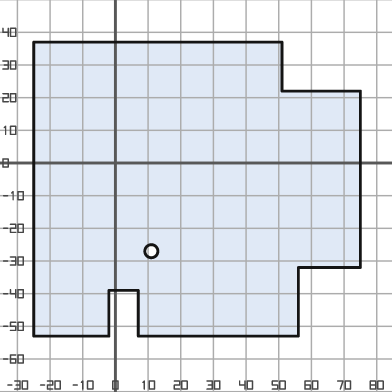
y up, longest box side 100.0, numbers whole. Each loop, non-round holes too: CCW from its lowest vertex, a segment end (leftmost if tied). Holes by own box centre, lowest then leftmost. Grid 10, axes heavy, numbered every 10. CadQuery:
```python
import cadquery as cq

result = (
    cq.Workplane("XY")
    .moveTo(-25.0, -53.0)
    .lineTo(-2.0, -53.0)
    .lineTo(-2.0, -39.0)
    .lineTo(7.0, -39.0)
    .lineTo(7.0, -53.0)
    .lineTo(56.0, -53.0)
    .lineTo(56.0, -32.0)
    .lineTo(75.0, -32.0)
    .lineTo(75.0, 22.0)
    .lineTo(51.0, 22.0)
    .lineTo(51.0, 37.0)
    .lineTo(-25.0, 37.0)
    .close()
    .moveTo(11.0, -27.0)
    .circle(2.0)
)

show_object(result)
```